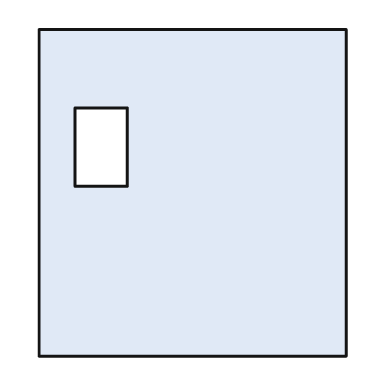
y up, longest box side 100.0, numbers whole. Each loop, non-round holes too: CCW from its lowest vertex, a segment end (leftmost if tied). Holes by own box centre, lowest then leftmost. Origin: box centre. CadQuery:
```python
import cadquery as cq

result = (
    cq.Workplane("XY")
    .moveTo(-47.0, -50.0)
    .lineTo(47.0, -50.0)
    .lineTo(47.0, 50.0)
    .lineTo(-47.0, 50.0)
    .close()
    .moveTo(-36.0, 2.0)
    .lineTo(-20.0, 2.0)
    .lineTo(-20.0, 26.0)
    .lineTo(-36.0, 26.0)
    .close()
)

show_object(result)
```